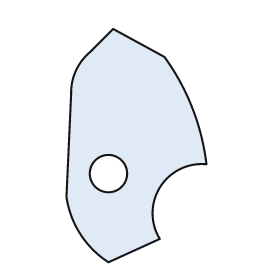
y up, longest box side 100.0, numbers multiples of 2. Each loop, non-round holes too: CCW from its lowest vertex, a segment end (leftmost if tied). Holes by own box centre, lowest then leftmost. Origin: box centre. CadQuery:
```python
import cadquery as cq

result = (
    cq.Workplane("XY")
    .moveTo(-12.0, -50.0)
    .lineTo(10.0, -40.0)
    .threePointArc((10.0, -18.0), (30.0, -8.0))
    .threePointArc((24.0, 16.0), (12.0, 38.0))
    .lineTo(-10.0, 50.0)
    .lineTo(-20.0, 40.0)
    .threePointArc((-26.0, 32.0), (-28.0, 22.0))
    .lineTo(-30.0, -22.0)
    .threePointArc((-24.0, -38.0), (-12.0, -50.0))
    .close()
    .moveTo(-12.0, -12.0)
    .circle(8.0)
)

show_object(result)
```